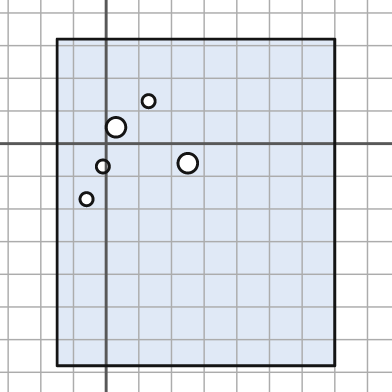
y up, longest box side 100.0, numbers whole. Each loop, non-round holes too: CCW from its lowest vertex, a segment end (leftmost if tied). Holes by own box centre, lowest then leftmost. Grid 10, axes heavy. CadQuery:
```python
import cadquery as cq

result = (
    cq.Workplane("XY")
    .moveTo(-15.0, -68.0)
    .lineTo(70.0, -68.0)
    .lineTo(70.0, 32.0)
    .lineTo(-15.0, 32.0)
    .close()
    .moveTo(-6.0, -17.0)
    .circle(2.0)
    .moveTo(-1.0, -7.0)
    .circle(2.0)
    .moveTo(25.0, -6.0)
    .circle(3.0)
    .moveTo(3.0, 5.0)
    .circle(3.0)
    .moveTo(13.0, 13.0)
    .circle(2.0)
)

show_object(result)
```